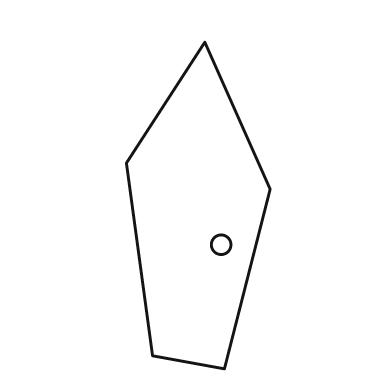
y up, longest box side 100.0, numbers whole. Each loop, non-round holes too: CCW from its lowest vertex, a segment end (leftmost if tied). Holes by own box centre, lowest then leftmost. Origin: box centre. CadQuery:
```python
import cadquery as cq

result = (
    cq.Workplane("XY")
    .moveTo(8.0, -50.0)
    .lineTo(22.0, 5.0)
    .lineTo(2.0, 50.0)
    .lineTo(-22.0, 13.0)
    .lineTo(-14.0, -46.0)
    .close()
    .moveTo(7.0, -12.0)
    .circle(3.0)
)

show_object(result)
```